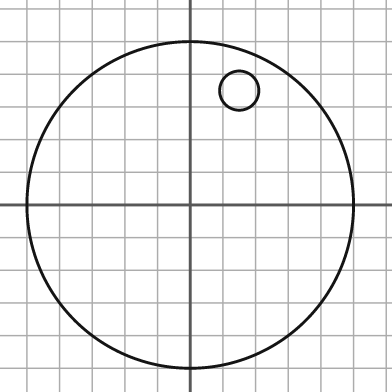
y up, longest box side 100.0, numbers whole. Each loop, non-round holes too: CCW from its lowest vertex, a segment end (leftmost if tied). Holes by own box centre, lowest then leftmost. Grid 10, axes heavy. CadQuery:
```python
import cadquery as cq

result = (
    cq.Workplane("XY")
    .moveTo(0.0, 0.0)
    .circle(50.0)
    .moveTo(15.0, 35.0)
    .circle(6.0)
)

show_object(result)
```